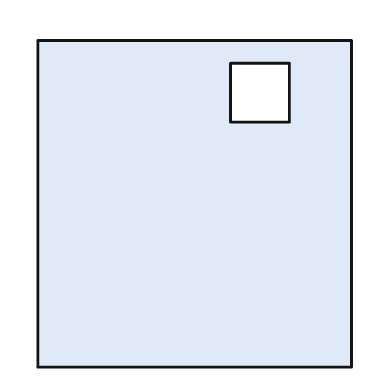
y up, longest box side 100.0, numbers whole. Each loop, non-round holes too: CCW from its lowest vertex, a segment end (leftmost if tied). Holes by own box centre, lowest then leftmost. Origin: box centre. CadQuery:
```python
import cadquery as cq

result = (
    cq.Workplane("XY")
    .moveTo(-48.0, -50.0)
    .lineTo(48.0, -50.0)
    .lineTo(48.0, 50.0)
    .lineTo(-48.0, 50.0)
    .close()
    .moveTo(11.0, 25.0)
    .lineTo(29.0, 25.0)
    .lineTo(29.0, 43.0)
    .lineTo(11.0, 43.0)
    .close()
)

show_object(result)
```